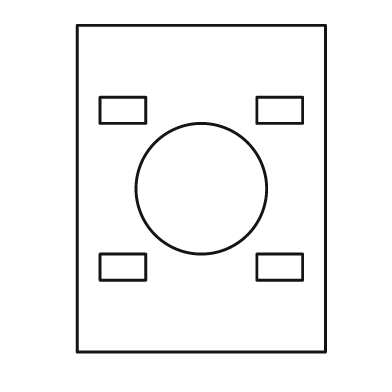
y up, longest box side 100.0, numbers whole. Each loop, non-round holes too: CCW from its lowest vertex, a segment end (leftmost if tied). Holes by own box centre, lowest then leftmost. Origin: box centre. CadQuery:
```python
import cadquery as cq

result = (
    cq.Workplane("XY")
    .moveTo(-38.0, -50.0)
    .lineTo(38.0, -50.0)
    .lineTo(38.0, 50.0)
    .lineTo(-38.0, 50.0)
    .close()
    .moveTo(-31.0, -28.0)
    .lineTo(-17.0, -28.0)
    .lineTo(-17.0, -20.0)
    .lineTo(-31.0, -20.0)
    .close()
    .moveTo(17.0, -28.0)
    .lineTo(31.0, -28.0)
    .lineTo(31.0, -20.0)
    .lineTo(17.0, -20.0)
    .close()
    .moveTo(0.0, 0.0)
    .circle(20.0)
    .moveTo(-31.0, 20.0)
    .lineTo(-17.0, 20.0)
    .lineTo(-17.0, 28.0)
    .lineTo(-31.0, 28.0)
    .close()
    .moveTo(17.0, 20.0)
    .lineTo(31.0, 20.0)
    .lineTo(31.0, 28.0)
    .lineTo(17.0, 28.0)
    .close()
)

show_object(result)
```